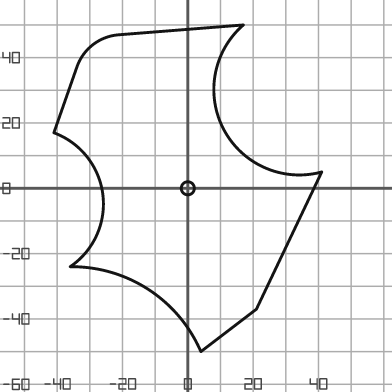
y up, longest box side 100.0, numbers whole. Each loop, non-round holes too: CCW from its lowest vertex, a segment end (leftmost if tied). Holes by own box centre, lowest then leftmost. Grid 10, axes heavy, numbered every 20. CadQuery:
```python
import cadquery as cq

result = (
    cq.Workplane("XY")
    .moveTo(4.0, -50.0)
    .lineTo(21.0, -37.0)
    .lineTo(41.0, 5.0)
    .threePointArc((11.0, 18.0), (17.0, 50.0))
    .lineTo(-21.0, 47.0)
    .threePointArc((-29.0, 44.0), (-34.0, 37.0))
    .lineTo(-41.0, 17.0)
    .threePointArc((-26.0, -2.0), (-36.0, -24.0))
    .threePointArc((-12.0, -31.0), (4.0, -50.0))
    .close()
    .moveTo(0.0, 0.0)
    .circle(2.0)
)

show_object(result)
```